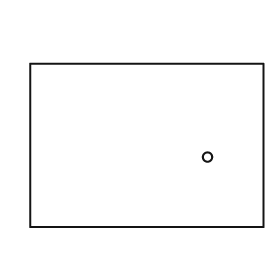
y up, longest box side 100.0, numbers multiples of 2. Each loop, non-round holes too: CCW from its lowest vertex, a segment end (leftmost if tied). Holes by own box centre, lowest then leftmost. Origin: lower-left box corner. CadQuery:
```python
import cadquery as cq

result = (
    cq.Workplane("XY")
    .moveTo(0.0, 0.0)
    .lineTo(100.0, 0.0)
    .lineTo(100.0, 70.0)
    .lineTo(0.0, 70.0)
    .close()
    .moveTo(76.0, 30.0)
    .circle(2.0)
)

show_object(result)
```